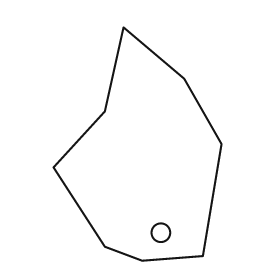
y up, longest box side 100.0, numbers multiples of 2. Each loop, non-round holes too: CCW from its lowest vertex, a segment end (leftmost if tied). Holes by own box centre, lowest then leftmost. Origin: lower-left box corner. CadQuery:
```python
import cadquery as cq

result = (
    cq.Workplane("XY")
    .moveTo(38.0, 0.0)
    .lineTo(64.0, 2.0)
    .lineTo(72.0, 50.0)
    .lineTo(56.0, 78.0)
    .lineTo(30.0, 100.0)
    .lineTo(22.0, 64.0)
    .lineTo(0.0, 40.0)
    .lineTo(22.0, 6.0)
    .close()
    .moveTo(46.0, 12.0)
    .circle(4.0)
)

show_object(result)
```